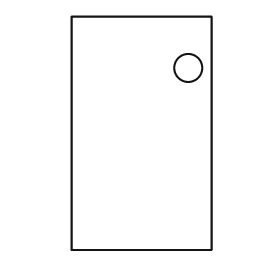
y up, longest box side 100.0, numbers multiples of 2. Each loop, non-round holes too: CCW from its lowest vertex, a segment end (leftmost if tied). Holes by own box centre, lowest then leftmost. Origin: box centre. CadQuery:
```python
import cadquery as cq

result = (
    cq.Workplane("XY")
    .moveTo(-30.0, -50.0)
    .lineTo(30.0, -50.0)
    .lineTo(30.0, 50.0)
    .lineTo(-30.0, 50.0)
    .close()
    .moveTo(20.0, 28.0)
    .circle(6.0)
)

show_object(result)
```